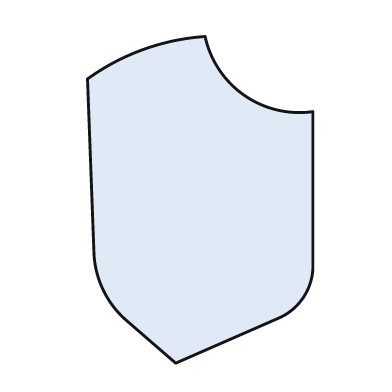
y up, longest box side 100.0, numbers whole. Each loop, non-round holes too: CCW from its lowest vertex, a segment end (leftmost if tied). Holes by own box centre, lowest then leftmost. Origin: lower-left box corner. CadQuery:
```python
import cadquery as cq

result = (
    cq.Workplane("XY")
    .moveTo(27.0, 0.0)
    .lineTo(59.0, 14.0)
    .threePointArc((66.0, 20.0), (69.0, 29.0))
    .lineTo(69.0, 77.0)
    .threePointArc((48.0, 82.0), (36.0, 100.0))
    .threePointArc((17.0, 96.0), (0.0, 87.0))
    .lineTo(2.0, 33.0)
    .threePointArc((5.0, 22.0), (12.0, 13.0))
    .close()
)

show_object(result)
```